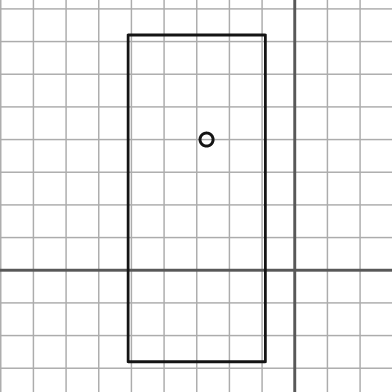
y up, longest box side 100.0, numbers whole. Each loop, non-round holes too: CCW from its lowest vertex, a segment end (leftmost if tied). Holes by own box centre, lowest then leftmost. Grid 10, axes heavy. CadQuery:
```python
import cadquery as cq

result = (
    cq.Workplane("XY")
    .moveTo(-51.0, -28.0)
    .lineTo(-9.0, -28.0)
    .lineTo(-9.0, 72.0)
    .lineTo(-51.0, 72.0)
    .close()
    .moveTo(-27.0, 40.0)
    .circle(2.0)
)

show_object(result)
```